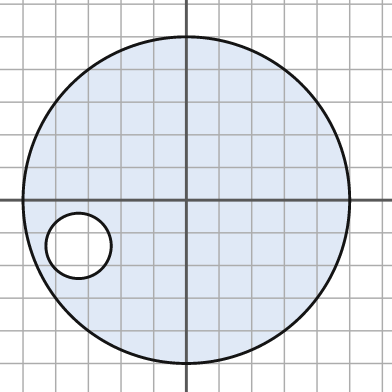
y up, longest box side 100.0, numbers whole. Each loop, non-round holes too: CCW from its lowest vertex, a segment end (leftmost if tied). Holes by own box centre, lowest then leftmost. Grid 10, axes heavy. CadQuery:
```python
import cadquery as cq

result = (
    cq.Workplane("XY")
    .moveTo(0.0, 0.0)
    .circle(50.0)
    .moveTo(-33.0, -14.0)
    .circle(10.0)
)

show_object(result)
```